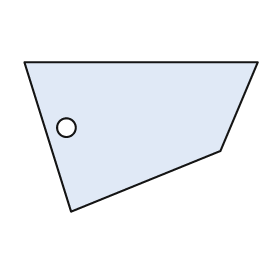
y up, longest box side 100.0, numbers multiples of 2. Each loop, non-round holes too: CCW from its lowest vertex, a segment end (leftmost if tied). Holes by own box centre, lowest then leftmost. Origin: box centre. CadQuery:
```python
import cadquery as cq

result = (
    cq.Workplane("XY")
    .moveTo(-30.0, -32.0)
    .lineTo(34.0, -6.0)
    .lineTo(50.0, 32.0)
    .lineTo(-50.0, 32.0)
    .close()
    .moveTo(-32.0, 4.0)
    .circle(4.0)
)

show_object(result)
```